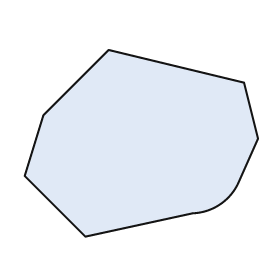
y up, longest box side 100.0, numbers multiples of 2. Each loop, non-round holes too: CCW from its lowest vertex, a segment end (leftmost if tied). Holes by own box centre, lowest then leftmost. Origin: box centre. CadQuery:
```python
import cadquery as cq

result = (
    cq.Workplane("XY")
    .moveTo(-24.0, -40.0)
    .lineTo(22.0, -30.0)
    .threePointArc((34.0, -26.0), (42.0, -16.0))
    .lineTo(50.0, 2.0)
    .lineTo(44.0, 26.0)
    .lineTo(-14.0, 40.0)
    .lineTo(-42.0, 12.0)
    .lineTo(-50.0, -14.0)
    .close()
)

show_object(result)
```